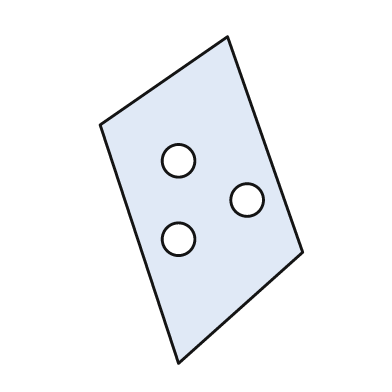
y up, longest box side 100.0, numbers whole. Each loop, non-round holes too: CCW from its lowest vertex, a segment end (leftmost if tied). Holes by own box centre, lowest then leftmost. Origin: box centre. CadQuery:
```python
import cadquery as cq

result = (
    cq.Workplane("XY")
    .moveTo(-7.0, -50.0)
    .lineTo(31.0, -16.0)
    .lineTo(8.0, 50.0)
    .lineTo(-31.0, 23.0)
    .close()
    .moveTo(-7.0, -12.0)
    .circle(5.0)
    .moveTo(14.0, 0.0)
    .circle(5.0)
    .moveTo(-7.0, 12.0)
    .circle(5.0)
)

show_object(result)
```